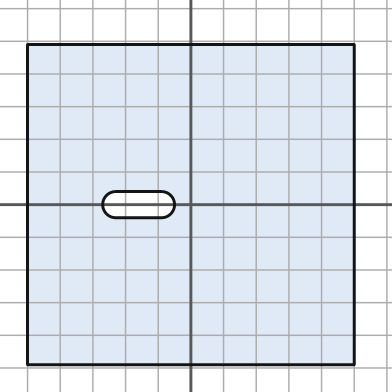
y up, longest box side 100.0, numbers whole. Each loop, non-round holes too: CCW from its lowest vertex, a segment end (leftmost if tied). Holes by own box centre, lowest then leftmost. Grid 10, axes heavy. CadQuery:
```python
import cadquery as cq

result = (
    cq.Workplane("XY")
    .moveTo(-50.0, -49.0)
    .lineTo(50.0, -49.0)
    .lineTo(50.0, 49.0)
    .lineTo(-50.0, 49.0)
    .close()
    .moveTo(-23.0, -4.0)
    .lineTo(-9.0, -4.0)
    .threePointArc((-5.0, 0.0), (-9.0, 4.0))
    .lineTo(-23.0, 4.0)
    .threePointArc((-27.0, 0.0), (-23.0, -4.0))
    .close()
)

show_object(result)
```